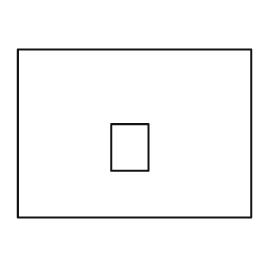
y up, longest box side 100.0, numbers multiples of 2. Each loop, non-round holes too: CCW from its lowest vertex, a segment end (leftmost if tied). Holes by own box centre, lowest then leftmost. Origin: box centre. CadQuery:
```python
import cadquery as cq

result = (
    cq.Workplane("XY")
    .moveTo(-50.0, -36.0)
    .lineTo(50.0, -36.0)
    .lineTo(50.0, 36.0)
    .lineTo(-50.0, 36.0)
    .close()
    .moveTo(-10.0, -16.0)
    .lineTo(6.0, -16.0)
    .lineTo(6.0, 4.0)
    .lineTo(-10.0, 4.0)
    .close()
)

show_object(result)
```